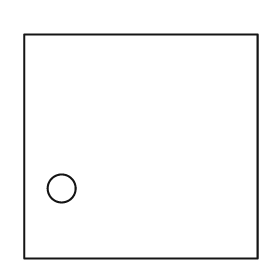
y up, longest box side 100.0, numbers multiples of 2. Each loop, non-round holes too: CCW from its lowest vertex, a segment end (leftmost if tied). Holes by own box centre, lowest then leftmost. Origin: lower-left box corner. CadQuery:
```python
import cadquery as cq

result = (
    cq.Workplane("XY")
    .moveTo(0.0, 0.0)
    .lineTo(100.0, 0.0)
    .lineTo(100.0, 96.0)
    .lineTo(0.0, 96.0)
    .close()
    .moveTo(16.0, 30.0)
    .circle(6.0)
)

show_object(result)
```